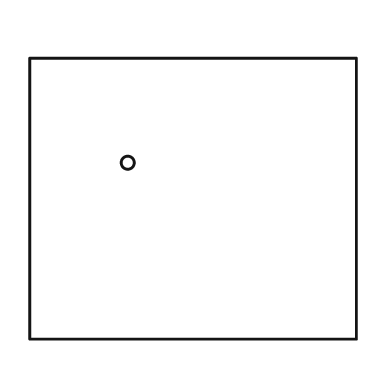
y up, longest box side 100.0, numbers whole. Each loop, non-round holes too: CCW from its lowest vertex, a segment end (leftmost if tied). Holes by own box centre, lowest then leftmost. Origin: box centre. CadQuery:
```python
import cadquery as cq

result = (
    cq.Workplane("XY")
    .moveTo(-50.0, -43.0)
    .lineTo(50.0, -43.0)
    .lineTo(50.0, 43.0)
    .lineTo(-50.0, 43.0)
    .close()
    .moveTo(-20.0, 11.0)
    .circle(2.0)
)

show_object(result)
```